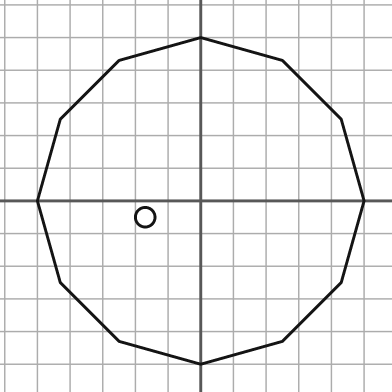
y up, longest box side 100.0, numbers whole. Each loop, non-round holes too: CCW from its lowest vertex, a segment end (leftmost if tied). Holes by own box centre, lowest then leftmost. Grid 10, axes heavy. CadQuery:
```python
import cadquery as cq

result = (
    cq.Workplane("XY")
    .moveTo(0.0, -50.0)
    .lineTo(25.0, -43.0)
    .lineTo(43.0, -25.0)
    .lineTo(50.0, 0.0)
    .lineTo(43.0, 25.0)
    .lineTo(25.0, 43.0)
    .lineTo(0.0, 50.0)
    .lineTo(-25.0, 43.0)
    .lineTo(-43.0, 25.0)
    .lineTo(-50.0, 0.0)
    .lineTo(-43.0, -25.0)
    .lineTo(-25.0, -43.0)
    .close()
    .moveTo(-17.0, -5.0)
    .circle(3.0)
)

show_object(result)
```